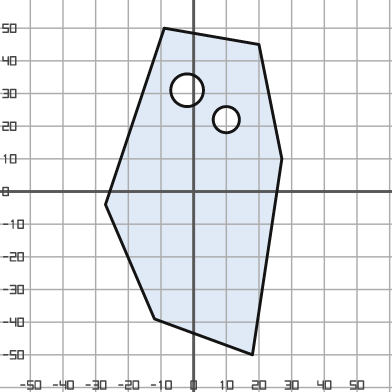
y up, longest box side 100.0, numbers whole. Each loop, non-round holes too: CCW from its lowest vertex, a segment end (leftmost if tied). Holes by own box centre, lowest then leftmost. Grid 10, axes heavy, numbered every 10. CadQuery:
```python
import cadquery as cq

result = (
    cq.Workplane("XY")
    .moveTo(18.0, -50.0)
    .lineTo(27.0, 10.0)
    .lineTo(20.0, 45.0)
    .lineTo(-9.0, 50.0)
    .lineTo(-27.0, -4.0)
    .lineTo(-12.0, -39.0)
    .close()
    .moveTo(10.0, 22.0)
    .circle(4.0)
    .moveTo(-2.0, 31.0)
    .circle(5.0)
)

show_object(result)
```